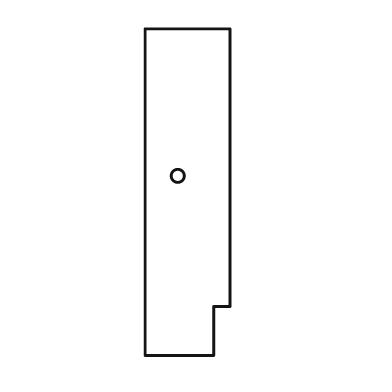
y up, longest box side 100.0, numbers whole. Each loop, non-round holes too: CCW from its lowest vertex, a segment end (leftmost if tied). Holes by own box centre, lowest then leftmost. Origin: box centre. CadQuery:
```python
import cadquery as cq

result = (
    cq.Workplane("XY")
    .moveTo(-13.0, -50.0)
    .lineTo(8.0, -50.0)
    .lineTo(8.0, -35.0)
    .lineTo(13.0, -35.0)
    .lineTo(13.0, 50.0)
    .lineTo(-13.0, 50.0)
    .close()
    .moveTo(-3.0, 5.0)
    .circle(2.0)
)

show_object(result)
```